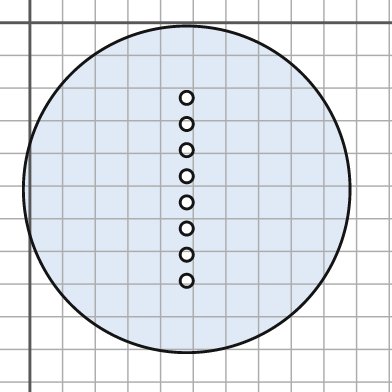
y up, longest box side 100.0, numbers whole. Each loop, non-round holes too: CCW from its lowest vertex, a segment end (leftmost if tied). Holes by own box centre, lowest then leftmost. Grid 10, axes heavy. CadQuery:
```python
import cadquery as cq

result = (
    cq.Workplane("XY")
    .moveTo(48.0, -51.0)
    .circle(50.0)
    .moveTo(48.0, -79.0)
    .circle(2.0)
    .moveTo(48.0, -71.0)
    .circle(2.0)
    .moveTo(48.0, -63.0)
    .circle(2.0)
    .moveTo(48.0, -55.0)
    .circle(2.0)
    .moveTo(48.0, -47.0)
    .circle(2.0)
    .moveTo(48.0, -39.0)
    .circle(2.0)
    .moveTo(48.0, -31.0)
    .circle(2.0)
    .moveTo(48.0, -23.0)
    .circle(2.0)
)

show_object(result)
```